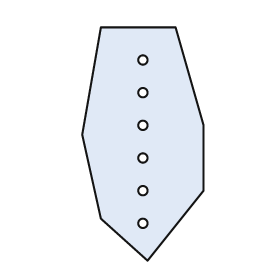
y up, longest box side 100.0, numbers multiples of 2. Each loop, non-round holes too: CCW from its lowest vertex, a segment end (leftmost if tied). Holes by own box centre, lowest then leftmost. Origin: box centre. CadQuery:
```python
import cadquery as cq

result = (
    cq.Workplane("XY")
    .moveTo(2.0, -50.0)
    .lineTo(26.0, -20.0)
    .lineTo(26.0, 8.0)
    .lineTo(14.0, 50.0)
    .lineTo(-18.0, 50.0)
    .lineTo(-26.0, 4.0)
    .lineTo(-18.0, -32.0)
    .close()
    .moveTo(0.0, -34.0)
    .circle(2.0)
    .moveTo(0.0, -20.0)
    .circle(2.0)
    .moveTo(0.0, -6.0)
    .circle(2.0)
    .moveTo(0.0, 8.0)
    .circle(2.0)
    .moveTo(0.0, 22.0)
    .circle(2.0)
    .moveTo(0.0, 36.0)
    .circle(2.0)
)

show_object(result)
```